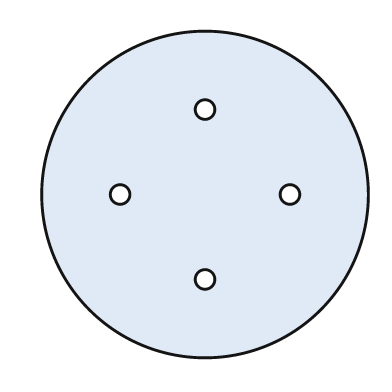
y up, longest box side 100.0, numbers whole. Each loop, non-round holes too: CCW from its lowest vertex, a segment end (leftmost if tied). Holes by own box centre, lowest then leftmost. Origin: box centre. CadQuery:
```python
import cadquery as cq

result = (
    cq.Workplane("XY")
    .moveTo(0.0, 0.0)
    .circle(50.0)
    .moveTo(0.0, -26.0)
    .circle(3.0)
    .moveTo(-26.0, 0.0)
    .circle(3.0)
    .moveTo(26.0, 0.0)
    .circle(3.0)
    .moveTo(0.0, 26.0)
    .circle(3.0)
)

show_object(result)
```